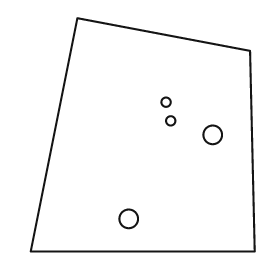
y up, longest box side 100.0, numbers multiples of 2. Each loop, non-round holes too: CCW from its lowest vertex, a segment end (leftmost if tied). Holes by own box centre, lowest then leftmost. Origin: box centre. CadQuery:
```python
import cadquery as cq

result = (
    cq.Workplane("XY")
    .moveTo(-48.0, -50.0)
    .lineTo(48.0, -50.0)
    .lineTo(46.0, 36.0)
    .lineTo(-28.0, 50.0)
    .close()
    .moveTo(-6.0, -36.0)
    .circle(4.0)
    .moveTo(30.0, 0.0)
    .circle(4.0)
    .moveTo(12.0, 6.0)
    .circle(2.0)
    .moveTo(10.0, 14.0)
    .circle(2.0)
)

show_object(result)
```